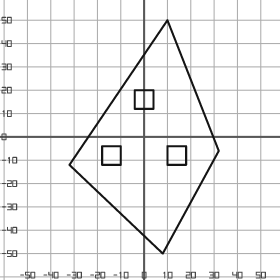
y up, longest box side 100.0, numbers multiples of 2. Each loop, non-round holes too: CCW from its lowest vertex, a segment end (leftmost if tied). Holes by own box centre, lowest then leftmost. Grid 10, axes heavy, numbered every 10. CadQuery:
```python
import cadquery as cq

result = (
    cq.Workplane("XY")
    .moveTo(8.0, -50.0)
    .lineTo(32.0, -6.0)
    .lineTo(10.0, 50.0)
    .lineTo(-32.0, -12.0)
    .close()
    .moveTo(-18.0, -12.0)
    .lineTo(-10.0, -12.0)
    .lineTo(-10.0, -4.0)
    .lineTo(-18.0, -4.0)
    .close()
    .moveTo(10.0, -12.0)
    .lineTo(18.0, -12.0)
    .lineTo(18.0, -4.0)
    .lineTo(10.0, -4.0)
    .close()
    .moveTo(-4.0, 12.0)
    .lineTo(4.0, 12.0)
    .lineTo(4.0, 20.0)
    .lineTo(-4.0, 20.0)
    .close()
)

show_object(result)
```